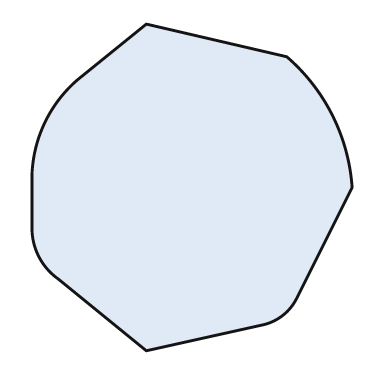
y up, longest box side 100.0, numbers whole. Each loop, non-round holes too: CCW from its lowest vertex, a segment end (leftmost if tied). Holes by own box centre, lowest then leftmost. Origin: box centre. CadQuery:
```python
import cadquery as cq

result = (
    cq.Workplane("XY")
    .moveTo(-14.0, -50.0)
    .lineTo(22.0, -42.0)
    .threePointArc((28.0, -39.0), (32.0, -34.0))
    .lineTo(49.0, 0.0)
    .threePointArc((43.0, 22.0), (29.0, 40.0))
    .lineTo(-14.0, 50.0)
    .lineTo(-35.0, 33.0)
    .threePointArc((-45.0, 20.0), (-49.0, 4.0))
    .lineTo(-49.0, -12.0)
    .threePointArc((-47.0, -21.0), (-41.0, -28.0))
    .close()
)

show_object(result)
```